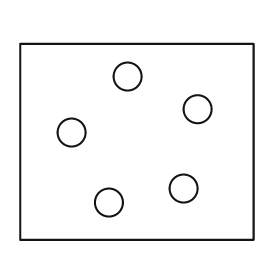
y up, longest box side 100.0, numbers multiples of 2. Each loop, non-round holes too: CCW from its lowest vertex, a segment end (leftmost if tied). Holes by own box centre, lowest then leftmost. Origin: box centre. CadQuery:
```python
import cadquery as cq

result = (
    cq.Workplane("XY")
    .moveTo(-50.0, -42.0)
    .lineTo(50.0, -42.0)
    .lineTo(50.0, 42.0)
    .lineTo(-50.0, 42.0)
    .close()
    .moveTo(-12.0, -26.0)
    .circle(6.0)
    .moveTo(20.0, -20.0)
    .circle(6.0)
    .moveTo(-28.0, 4.0)
    .circle(6.0)
    .moveTo(26.0, 14.0)
    .circle(6.0)
    .moveTo(-4.0, 28.0)
    .circle(6.0)
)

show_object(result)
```